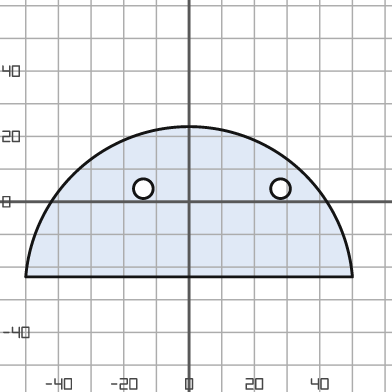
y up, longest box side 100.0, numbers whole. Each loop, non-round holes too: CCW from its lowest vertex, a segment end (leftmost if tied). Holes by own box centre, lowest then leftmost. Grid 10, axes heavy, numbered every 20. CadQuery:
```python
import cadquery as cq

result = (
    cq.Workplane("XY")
    .moveTo(-50.0, -23.0)
    .lineTo(50.0, -23.0)
    .threePointArc((0.0, 23.0), (-50.0, -23.0))
    .close()
    .moveTo(-14.0, 4.0)
    .circle(3.0)
    .moveTo(28.0, 4.0)
    .circle(3.0)
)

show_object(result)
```